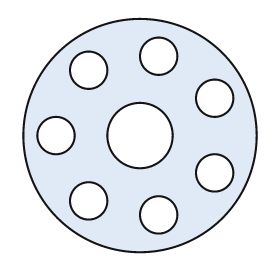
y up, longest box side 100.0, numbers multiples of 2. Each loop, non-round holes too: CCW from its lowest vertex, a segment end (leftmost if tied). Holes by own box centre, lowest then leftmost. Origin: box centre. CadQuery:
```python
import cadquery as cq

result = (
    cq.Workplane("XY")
    .moveTo(0.0, 0.0)
    .circle(50.0)
    .moveTo(8.0, -34.0)
    .circle(8.0)
    .moveTo(-22.0, -28.0)
    .circle(8.0)
    .moveTo(32.0, -16.0)
    .circle(8.0)
    .moveTo(-36.0, 0.0)
    .circle(8.0)
    .moveTo(0.0, 0.0)
    .circle(14.0)
    .moveTo(32.0, 16.0)
    .circle(8.0)
    .moveTo(-22.0, 28.0)
    .circle(8.0)
    .moveTo(8.0, 34.0)
    .circle(8.0)
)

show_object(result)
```